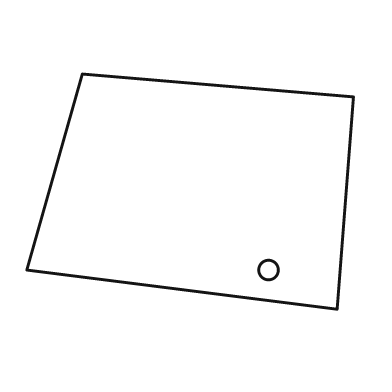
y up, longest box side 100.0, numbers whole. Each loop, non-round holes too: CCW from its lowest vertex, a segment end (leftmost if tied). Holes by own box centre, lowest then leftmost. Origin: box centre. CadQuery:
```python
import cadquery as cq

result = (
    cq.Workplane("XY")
    .moveTo(45.0, -36.0)
    .lineTo(50.0, 29.0)
    .lineTo(-33.0, 36.0)
    .lineTo(-50.0, -24.0)
    .close()
    .moveTo(24.0, -24.0)
    .circle(3.0)
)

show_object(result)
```